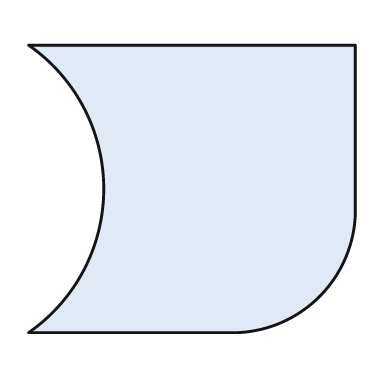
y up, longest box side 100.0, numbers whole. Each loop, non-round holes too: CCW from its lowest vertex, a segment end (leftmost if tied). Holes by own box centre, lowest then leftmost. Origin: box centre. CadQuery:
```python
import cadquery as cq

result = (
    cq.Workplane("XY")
    .moveTo(-50.0, -44.0)
    .lineTo(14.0, -44.0)
    .threePointArc((39.0, -33.0), (50.0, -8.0))
    .lineTo(50.0, 44.0)
    .lineTo(-50.0, 44.0)
    .threePointArc((-27.0, 0.0), (-50.0, -44.0))
    .close()
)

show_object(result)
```